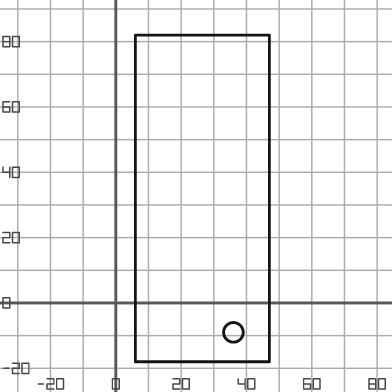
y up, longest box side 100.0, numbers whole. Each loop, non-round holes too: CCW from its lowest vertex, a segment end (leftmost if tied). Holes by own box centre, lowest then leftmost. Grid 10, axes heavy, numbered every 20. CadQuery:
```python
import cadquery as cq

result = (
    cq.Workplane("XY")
    .moveTo(6.0, -18.0)
    .lineTo(47.0, -18.0)
    .lineTo(47.0, 82.0)
    .lineTo(6.0, 82.0)
    .close()
    .moveTo(36.0, -9.0)
    .circle(3.0)
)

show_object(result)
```